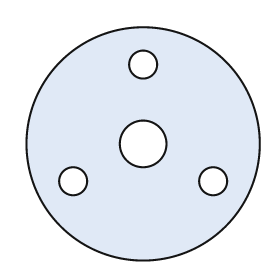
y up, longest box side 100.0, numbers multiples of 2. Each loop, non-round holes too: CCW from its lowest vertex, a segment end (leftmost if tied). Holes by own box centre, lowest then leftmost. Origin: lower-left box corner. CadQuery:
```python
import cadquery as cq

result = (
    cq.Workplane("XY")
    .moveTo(50.0, 50.0)
    .circle(50.0)
    .moveTo(20.0, 34.0)
    .circle(6.0)
    .moveTo(80.0, 34.0)
    .circle(6.0)
    .moveTo(50.0, 50.0)
    .circle(10.0)
    .moveTo(50.0, 84.0)
    .circle(6.0)
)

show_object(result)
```